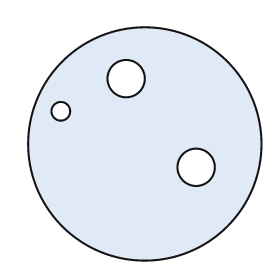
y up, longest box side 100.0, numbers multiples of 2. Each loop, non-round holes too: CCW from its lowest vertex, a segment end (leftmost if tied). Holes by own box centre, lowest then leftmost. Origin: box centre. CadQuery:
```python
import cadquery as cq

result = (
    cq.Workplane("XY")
    .moveTo(0.0, 0.0)
    .circle(50.0)
    .moveTo(22.0, -10.0)
    .circle(8.0)
    .moveTo(-36.0, 14.0)
    .circle(4.0)
    .moveTo(-8.0, 28.0)
    .circle(8.0)
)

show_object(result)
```